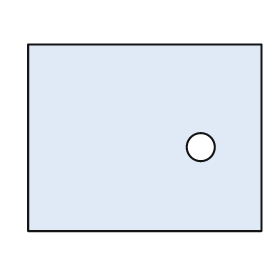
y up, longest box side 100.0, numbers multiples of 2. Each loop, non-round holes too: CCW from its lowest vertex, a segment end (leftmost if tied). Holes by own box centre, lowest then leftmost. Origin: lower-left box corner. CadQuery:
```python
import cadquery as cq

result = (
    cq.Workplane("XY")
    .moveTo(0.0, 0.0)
    .lineTo(100.0, 0.0)
    .lineTo(100.0, 80.0)
    .lineTo(0.0, 80.0)
    .close()
    .moveTo(74.0, 36.0)
    .circle(6.0)
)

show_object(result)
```